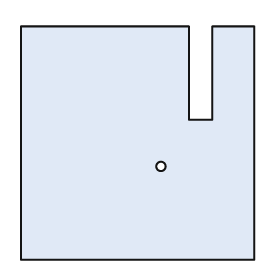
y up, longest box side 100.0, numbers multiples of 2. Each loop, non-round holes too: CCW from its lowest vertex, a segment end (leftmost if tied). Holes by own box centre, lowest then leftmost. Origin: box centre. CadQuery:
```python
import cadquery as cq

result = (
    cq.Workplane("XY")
    .moveTo(-50.0, -50.0)
    .lineTo(50.0, -50.0)
    .lineTo(50.0, 50.0)
    .lineTo(32.0, 50.0)
    .lineTo(32.0, 10.0)
    .lineTo(22.0, 10.0)
    .lineTo(22.0, 50.0)
    .lineTo(-50.0, 50.0)
    .close()
    .moveTo(10.0, -10.0)
    .circle(2.0)
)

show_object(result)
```